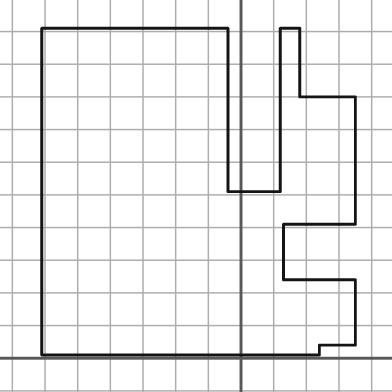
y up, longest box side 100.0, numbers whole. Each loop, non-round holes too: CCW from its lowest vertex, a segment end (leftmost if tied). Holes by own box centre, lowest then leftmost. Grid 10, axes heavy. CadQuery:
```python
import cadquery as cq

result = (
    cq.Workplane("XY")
    .moveTo(-61.0, 1.0)
    .lineTo(24.0, 1.0)
    .lineTo(24.0, 4.0)
    .lineTo(35.0, 4.0)
    .lineTo(35.0, 24.0)
    .lineTo(13.0, 24.0)
    .lineTo(13.0, 41.0)
    .lineTo(35.0, 41.0)
    .lineTo(35.0, 80.0)
    .lineTo(18.0, 80.0)
    .lineTo(18.0, 101.0)
    .lineTo(12.0, 101.0)
    .lineTo(12.0, 51.0)
    .lineTo(-4.0, 51.0)
    .lineTo(-4.0, 101.0)
    .lineTo(-61.0, 101.0)
    .close()
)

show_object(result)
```